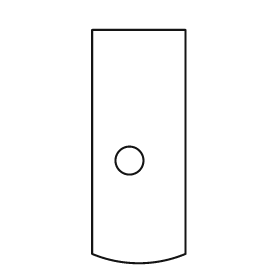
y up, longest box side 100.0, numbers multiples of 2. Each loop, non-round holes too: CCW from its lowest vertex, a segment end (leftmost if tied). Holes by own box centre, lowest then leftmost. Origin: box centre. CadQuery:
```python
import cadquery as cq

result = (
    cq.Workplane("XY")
    .moveTo(-20.0, -46.0)
    .threePointArc((0.0, -50.0), (20.0, -46.0))
    .lineTo(20.0, 50.0)
    .lineTo(-20.0, 50.0)
    .close()
    .moveTo(-4.0, -6.0)
    .circle(6.0)
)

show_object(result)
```